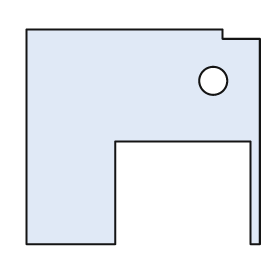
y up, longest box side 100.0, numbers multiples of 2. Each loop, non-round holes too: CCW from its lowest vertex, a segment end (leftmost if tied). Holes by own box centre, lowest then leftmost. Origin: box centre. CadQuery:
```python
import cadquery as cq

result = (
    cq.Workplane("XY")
    .moveTo(-50.0, -46.0)
    .lineTo(-12.0, -46.0)
    .lineTo(-12.0, -2.0)
    .lineTo(46.0, -2.0)
    .lineTo(46.0, -46.0)
    .lineTo(50.0, -46.0)
    .lineTo(50.0, 42.0)
    .lineTo(34.0, 42.0)
    .lineTo(34.0, 46.0)
    .lineTo(-50.0, 46.0)
    .close()
    .moveTo(30.0, 24.0)
    .circle(6.0)
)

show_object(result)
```